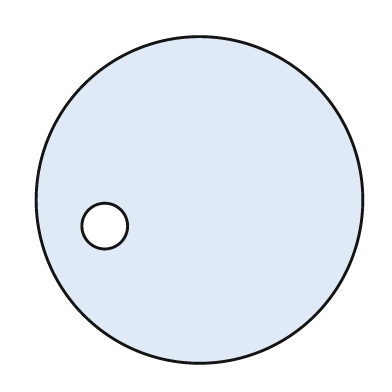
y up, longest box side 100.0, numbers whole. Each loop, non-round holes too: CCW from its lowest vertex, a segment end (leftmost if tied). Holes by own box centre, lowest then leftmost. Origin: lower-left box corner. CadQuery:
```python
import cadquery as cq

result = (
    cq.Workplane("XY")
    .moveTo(50.0, 50.0)
    .circle(50.0)
    .moveTo(21.0, 42.0)
    .circle(7.0)
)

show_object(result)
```